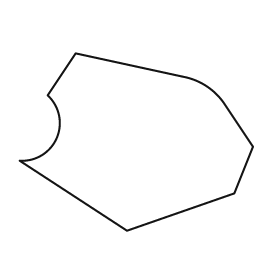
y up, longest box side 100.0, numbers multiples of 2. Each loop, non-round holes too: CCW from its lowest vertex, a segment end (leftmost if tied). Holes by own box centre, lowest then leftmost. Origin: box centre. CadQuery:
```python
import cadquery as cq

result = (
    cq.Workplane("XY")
    .moveTo(-4.0, -38.0)
    .lineTo(42.0, -22.0)
    .lineTo(50.0, -2.0)
    .lineTo(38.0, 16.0)
    .threePointArc((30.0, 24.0), (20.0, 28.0))
    .lineTo(-26.0, 38.0)
    .lineTo(-38.0, 20.0)
    .threePointArc((-34.0, 2.0), (-50.0, -8.0))
    .close()
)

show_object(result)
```